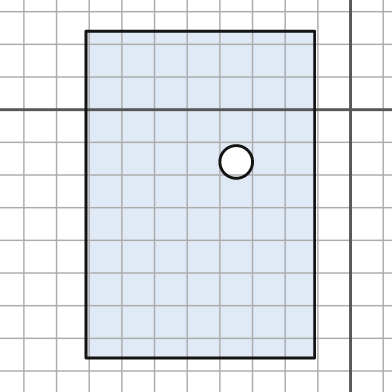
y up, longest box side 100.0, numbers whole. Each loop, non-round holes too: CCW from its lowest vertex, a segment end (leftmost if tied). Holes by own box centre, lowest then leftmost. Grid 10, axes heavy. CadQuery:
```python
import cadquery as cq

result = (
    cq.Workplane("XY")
    .moveTo(-81.0, -76.0)
    .lineTo(-11.0, -76.0)
    .lineTo(-11.0, 24.0)
    .lineTo(-81.0, 24.0)
    .close()
    .moveTo(-35.0, -16.0)
    .circle(5.0)
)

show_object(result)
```